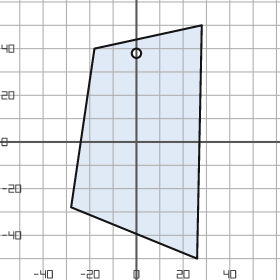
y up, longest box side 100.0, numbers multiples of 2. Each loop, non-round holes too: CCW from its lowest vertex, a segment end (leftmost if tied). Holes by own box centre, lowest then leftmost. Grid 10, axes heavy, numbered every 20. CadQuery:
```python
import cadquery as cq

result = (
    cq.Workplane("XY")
    .moveTo(26.0, -50.0)
    .lineTo(28.0, 50.0)
    .lineTo(-18.0, 40.0)
    .lineTo(-28.0, -28.0)
    .close()
    .moveTo(0.0, 38.0)
    .circle(2.0)
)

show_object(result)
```